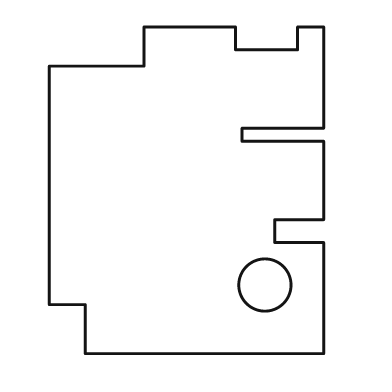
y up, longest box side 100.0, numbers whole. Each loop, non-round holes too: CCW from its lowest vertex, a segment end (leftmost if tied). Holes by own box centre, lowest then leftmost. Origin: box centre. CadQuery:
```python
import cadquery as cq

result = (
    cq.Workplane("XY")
    .moveTo(-31.0, -50.0)
    .lineTo(42.0, -50.0)
    .lineTo(42.0, -16.0)
    .lineTo(27.0, -16.0)
    .lineTo(27.0, -9.0)
    .lineTo(42.0, -9.0)
    .lineTo(42.0, 15.0)
    .lineTo(17.0, 15.0)
    .lineTo(17.0, 19.0)
    .lineTo(42.0, 19.0)
    .lineTo(42.0, 50.0)
    .lineTo(34.0, 50.0)
    .lineTo(34.0, 43.0)
    .lineTo(15.0, 43.0)
    .lineTo(15.0, 50.0)
    .lineTo(-13.0, 50.0)
    .lineTo(-13.0, 38.0)
    .lineTo(-42.0, 38.0)
    .lineTo(-42.0, -35.0)
    .lineTo(-31.0, -35.0)
    .close()
    .moveTo(24.0, -29.0)
    .circle(8.0)
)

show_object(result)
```